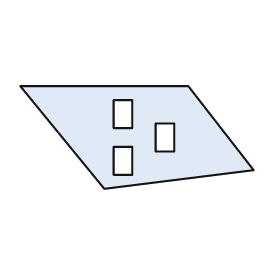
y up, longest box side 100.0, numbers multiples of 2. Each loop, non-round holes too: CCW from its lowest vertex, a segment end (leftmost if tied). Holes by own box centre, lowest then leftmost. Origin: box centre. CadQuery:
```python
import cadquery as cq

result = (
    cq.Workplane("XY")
    .moveTo(-14.0, -22.0)
    .lineTo(50.0, -14.0)
    .lineTo(22.0, 22.0)
    .lineTo(-50.0, 22.0)
    .close()
    .moveTo(-10.0, -16.0)
    .lineTo(-2.0, -16.0)
    .lineTo(-2.0, -4.0)
    .lineTo(-10.0, -4.0)
    .close()
    .moveTo(8.0, -6.0)
    .lineTo(16.0, -6.0)
    .lineTo(16.0, 6.0)
    .lineTo(8.0, 6.0)
    .close()
    .moveTo(-10.0, 4.0)
    .lineTo(-2.0, 4.0)
    .lineTo(-2.0, 16.0)
    .lineTo(-10.0, 16.0)
    .close()
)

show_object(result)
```